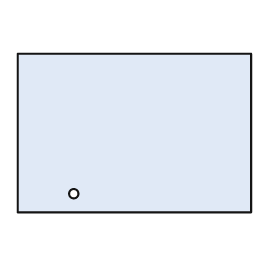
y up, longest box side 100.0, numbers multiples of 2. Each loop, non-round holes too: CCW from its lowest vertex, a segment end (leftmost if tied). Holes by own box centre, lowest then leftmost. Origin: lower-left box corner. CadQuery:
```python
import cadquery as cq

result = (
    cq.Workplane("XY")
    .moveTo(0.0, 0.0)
    .lineTo(100.0, 0.0)
    .lineTo(100.0, 68.0)
    .lineTo(0.0, 68.0)
    .close()
    .moveTo(24.0, 8.0)
    .circle(2.0)
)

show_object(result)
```